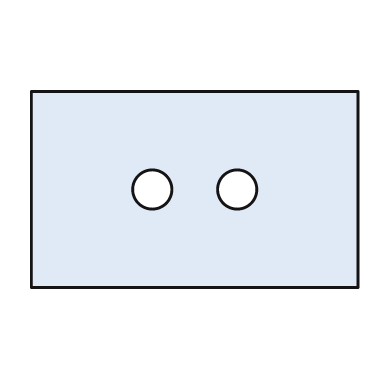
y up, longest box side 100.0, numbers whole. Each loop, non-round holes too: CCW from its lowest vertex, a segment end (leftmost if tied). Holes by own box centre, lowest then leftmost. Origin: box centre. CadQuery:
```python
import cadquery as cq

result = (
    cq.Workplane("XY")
    .moveTo(-50.0, -30.0)
    .lineTo(50.0, -30.0)
    .lineTo(50.0, 30.0)
    .lineTo(-50.0, 30.0)
    .close()
    .moveTo(-13.0, 0.0)
    .circle(6.0)
    .moveTo(13.0, 0.0)
    .circle(6.0)
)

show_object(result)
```